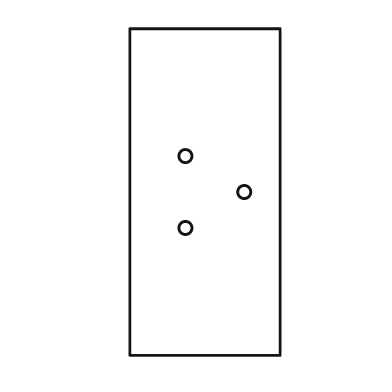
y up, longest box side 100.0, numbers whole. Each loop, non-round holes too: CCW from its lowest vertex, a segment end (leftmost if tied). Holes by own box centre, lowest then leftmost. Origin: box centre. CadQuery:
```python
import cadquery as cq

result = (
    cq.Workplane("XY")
    .moveTo(-23.0, -50.0)
    .lineTo(23.0, -50.0)
    .lineTo(23.0, 50.0)
    .lineTo(-23.0, 50.0)
    .close()
    .moveTo(-6.0, -11.0)
    .circle(2.0)
    .moveTo(12.0, 0.0)
    .circle(2.0)
    .moveTo(-6.0, 11.0)
    .circle(2.0)
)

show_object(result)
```